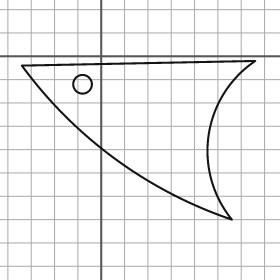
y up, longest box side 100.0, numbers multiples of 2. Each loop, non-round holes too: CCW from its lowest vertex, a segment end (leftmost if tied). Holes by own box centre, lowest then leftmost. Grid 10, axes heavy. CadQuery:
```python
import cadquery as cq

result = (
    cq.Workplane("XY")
    .moveTo(56.0, -70.0)
    .threePointArc((46.0, -34.0), (66.0, -2.0))
    .lineTo(-34.0, -4.0)
    .threePointArc((6.0, -44.0), (56.0, -70.0))
    .close()
    .moveTo(-8.0, -12.0)
    .circle(4.0)
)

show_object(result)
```